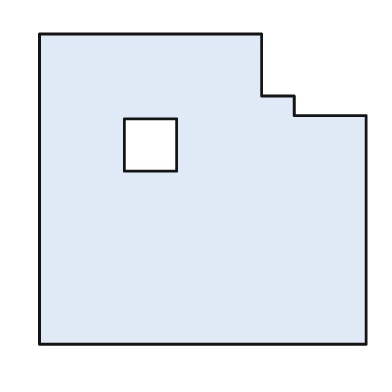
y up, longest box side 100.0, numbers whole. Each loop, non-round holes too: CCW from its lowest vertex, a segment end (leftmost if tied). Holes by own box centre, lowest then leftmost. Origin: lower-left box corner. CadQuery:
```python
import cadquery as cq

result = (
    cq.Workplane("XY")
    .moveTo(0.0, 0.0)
    .lineTo(100.0, 0.0)
    .lineTo(100.0, 70.0)
    .lineTo(78.0, 70.0)
    .lineTo(78.0, 76.0)
    .lineTo(68.0, 76.0)
    .lineTo(68.0, 95.0)
    .lineTo(0.0, 95.0)
    .close()
    .moveTo(26.0, 53.0)
    .lineTo(42.0, 53.0)
    .lineTo(42.0, 69.0)
    .lineTo(26.0, 69.0)
    .close()
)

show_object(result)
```